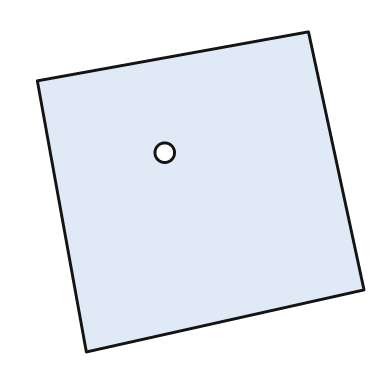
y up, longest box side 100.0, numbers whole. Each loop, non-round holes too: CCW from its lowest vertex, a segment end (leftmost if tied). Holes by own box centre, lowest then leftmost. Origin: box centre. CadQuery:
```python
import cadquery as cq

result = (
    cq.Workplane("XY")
    .moveTo(-35.0, -49.0)
    .lineTo(50.0, -30.0)
    .lineTo(33.0, 49.0)
    .lineTo(-50.0, 34.0)
    .close()
    .moveTo(-11.0, 12.0)
    .circle(3.0)
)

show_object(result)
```